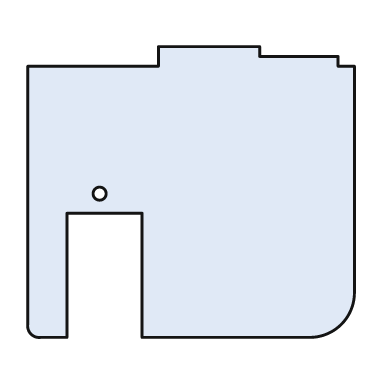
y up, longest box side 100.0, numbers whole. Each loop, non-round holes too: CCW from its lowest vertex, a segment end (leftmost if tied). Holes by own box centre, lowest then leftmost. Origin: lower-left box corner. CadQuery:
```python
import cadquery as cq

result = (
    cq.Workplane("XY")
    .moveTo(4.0, 0.0)
    .lineTo(12.0, 0.0)
    .lineTo(12.0, 38.0)
    .lineTo(35.0, 38.0)
    .lineTo(35.0, 0.0)
    .lineTo(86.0, 0.0)
    .threePointArc((96.0, 4.0), (100.0, 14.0))
    .lineTo(100.0, 83.0)
    .lineTo(95.0, 83.0)
    .lineTo(95.0, 86.0)
    .lineTo(71.0, 86.0)
    .lineTo(71.0, 89.0)
    .lineTo(40.0, 89.0)
    .lineTo(40.0, 83.0)
    .lineTo(0.0, 83.0)
    .lineTo(0.0, 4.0)
    .threePointArc((1.0, 1.0), (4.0, 0.0))
    .close()
    .moveTo(22.0, 44.0)
    .circle(2.0)
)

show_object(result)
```